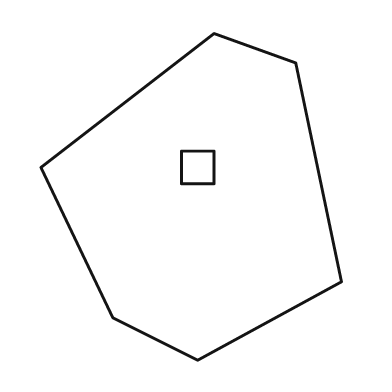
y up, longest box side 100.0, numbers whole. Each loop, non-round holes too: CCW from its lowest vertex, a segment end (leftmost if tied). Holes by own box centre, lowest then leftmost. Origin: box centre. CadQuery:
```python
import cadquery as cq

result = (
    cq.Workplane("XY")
    .moveTo(2.0, -50.0)
    .lineTo(46.0, -26.0)
    .lineTo(32.0, 41.0)
    .lineTo(7.0, 50.0)
    .lineTo(-46.0, 9.0)
    .lineTo(-24.0, -37.0)
    .close()
    .moveTo(-3.0, 4.0)
    .lineTo(7.0, 4.0)
    .lineTo(7.0, 14.0)
    .lineTo(-3.0, 14.0)
    .close()
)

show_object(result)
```